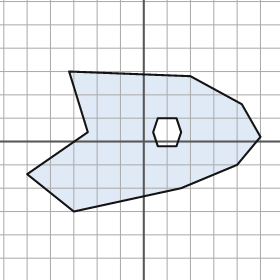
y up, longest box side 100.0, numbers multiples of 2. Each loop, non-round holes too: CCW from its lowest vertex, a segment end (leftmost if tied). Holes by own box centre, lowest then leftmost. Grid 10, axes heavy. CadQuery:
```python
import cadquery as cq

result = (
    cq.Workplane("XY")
    .moveTo(-30.0, -30.0)
    .lineTo(16.0, -20.0)
    .lineTo(40.0, -10.0)
    .lineTo(50.0, 2.0)
    .lineTo(42.0, 16.0)
    .lineTo(20.0, 28.0)
    .lineTo(-32.0, 30.0)
    .lineTo(-24.0, 4.0)
    .lineTo(-50.0, -14.0)
    .close()
    .moveTo(6.0, -2.0)
    .lineTo(14.0, -2.0)
    .lineTo(16.0, 4.0)
    .lineTo(14.0, 10.0)
    .lineTo(6.0, 10.0)
    .lineTo(4.0, 4.0)
    .close()
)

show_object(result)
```